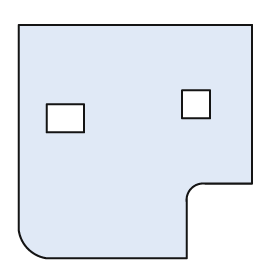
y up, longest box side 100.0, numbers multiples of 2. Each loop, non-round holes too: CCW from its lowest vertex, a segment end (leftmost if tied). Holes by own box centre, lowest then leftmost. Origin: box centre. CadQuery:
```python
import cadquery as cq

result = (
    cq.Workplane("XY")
    .moveTo(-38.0, -50.0)
    .lineTo(22.0, -50.0)
    .lineTo(22.0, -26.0)
    .threePointArc((24.0, -20.0), (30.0, -18.0))
    .lineTo(50.0, -18.0)
    .lineTo(50.0, 50.0)
    .lineTo(-50.0, 50.0)
    .lineTo(-50.0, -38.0)
    .threePointArc((-46.0, -46.0), (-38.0, -50.0))
    .close()
    .moveTo(-38.0, 4.0)
    .lineTo(-22.0, 4.0)
    .lineTo(-22.0, 16.0)
    .lineTo(-38.0, 16.0)
    .close()
    .moveTo(20.0, 10.0)
    .lineTo(32.0, 10.0)
    .lineTo(32.0, 22.0)
    .lineTo(20.0, 22.0)
    .close()
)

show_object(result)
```